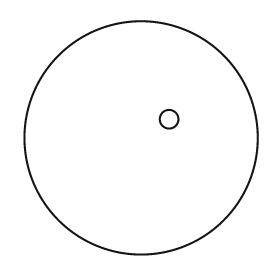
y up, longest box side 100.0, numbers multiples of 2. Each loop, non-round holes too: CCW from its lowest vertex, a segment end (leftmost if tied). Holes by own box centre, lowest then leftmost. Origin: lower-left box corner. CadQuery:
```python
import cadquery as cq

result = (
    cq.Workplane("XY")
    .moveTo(50.0, 50.0)
    .circle(50.0)
    .moveTo(62.0, 58.0)
    .circle(4.0)
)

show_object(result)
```